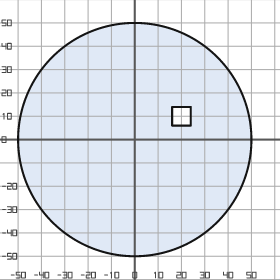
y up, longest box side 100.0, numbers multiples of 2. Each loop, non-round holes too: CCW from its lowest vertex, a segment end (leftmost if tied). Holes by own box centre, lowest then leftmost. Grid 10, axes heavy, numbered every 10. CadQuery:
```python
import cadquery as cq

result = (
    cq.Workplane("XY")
    .moveTo(0.0, 0.0)
    .circle(50.0)
    .moveTo(16.0, 6.0)
    .lineTo(24.0, 6.0)
    .lineTo(24.0, 14.0)
    .lineTo(16.0, 14.0)
    .close()
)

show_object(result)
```